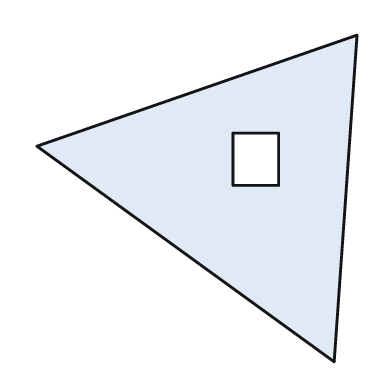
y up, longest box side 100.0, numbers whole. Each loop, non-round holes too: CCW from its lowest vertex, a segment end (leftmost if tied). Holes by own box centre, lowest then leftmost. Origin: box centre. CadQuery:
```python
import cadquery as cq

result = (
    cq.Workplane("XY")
    .moveTo(42.0, -50.0)
    .lineTo(49.0, 50.0)
    .lineTo(-49.0, 16.0)
    .close()
    .moveTo(11.0, 4.0)
    .lineTo(25.0, 4.0)
    .lineTo(25.0, 20.0)
    .lineTo(11.0, 20.0)
    .close()
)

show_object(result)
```